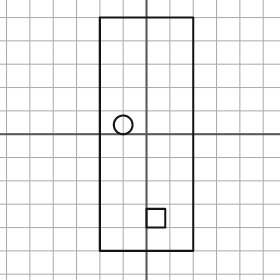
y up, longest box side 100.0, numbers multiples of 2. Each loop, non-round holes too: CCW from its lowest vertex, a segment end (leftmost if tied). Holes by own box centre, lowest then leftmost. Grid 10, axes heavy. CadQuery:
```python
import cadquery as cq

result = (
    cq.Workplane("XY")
    .moveTo(-20.0, -50.0)
    .lineTo(20.0, -50.0)
    .lineTo(20.0, 50.0)
    .lineTo(-20.0, 50.0)
    .close()
    .moveTo(0.0, -40.0)
    .lineTo(8.0, -40.0)
    .lineTo(8.0, -32.0)
    .lineTo(0.0, -32.0)
    .close()
    .moveTo(-10.0, 4.0)
    .circle(4.0)
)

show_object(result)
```